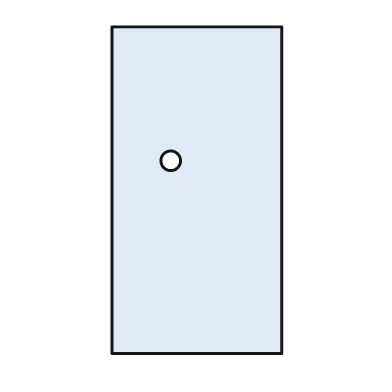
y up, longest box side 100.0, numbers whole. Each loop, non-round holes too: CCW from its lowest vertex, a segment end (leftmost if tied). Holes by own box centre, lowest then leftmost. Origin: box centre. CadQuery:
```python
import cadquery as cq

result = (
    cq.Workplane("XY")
    .moveTo(-26.0, -50.0)
    .lineTo(26.0, -50.0)
    .lineTo(26.0, 50.0)
    .lineTo(-26.0, 50.0)
    .close()
    .moveTo(-8.0, 9.0)
    .circle(3.0)
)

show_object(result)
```